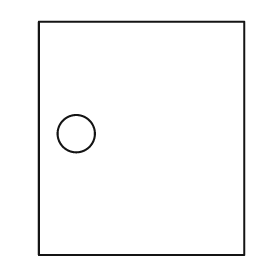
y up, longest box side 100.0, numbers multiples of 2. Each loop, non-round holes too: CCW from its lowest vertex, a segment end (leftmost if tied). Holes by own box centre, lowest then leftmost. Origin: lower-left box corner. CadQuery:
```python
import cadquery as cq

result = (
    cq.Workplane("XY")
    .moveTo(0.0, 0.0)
    .lineTo(88.0, 0.0)
    .lineTo(88.0, 100.0)
    .lineTo(0.0, 100.0)
    .close()
    .moveTo(16.0, 52.0)
    .circle(8.0)
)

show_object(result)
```